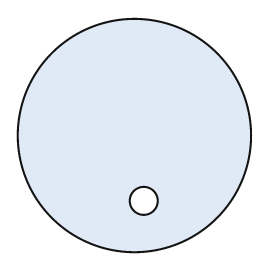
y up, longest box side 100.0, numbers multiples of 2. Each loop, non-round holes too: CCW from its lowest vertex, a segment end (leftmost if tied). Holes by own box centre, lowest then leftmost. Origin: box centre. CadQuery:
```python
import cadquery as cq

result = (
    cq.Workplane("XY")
    .moveTo(0.0, 0.0)
    .circle(50.0)
    .moveTo(4.0, -28.0)
    .circle(6.0)
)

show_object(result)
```